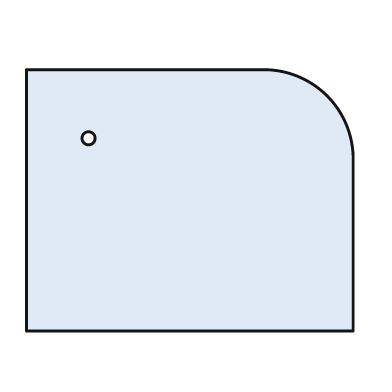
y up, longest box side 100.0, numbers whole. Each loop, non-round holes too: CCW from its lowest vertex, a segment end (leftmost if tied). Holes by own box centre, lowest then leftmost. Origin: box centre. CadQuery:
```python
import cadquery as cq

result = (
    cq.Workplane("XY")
    .moveTo(-50.0, -40.0)
    .lineTo(50.0, -40.0)
    .lineTo(50.0, 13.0)
    .threePointArc((42.0, 32.0), (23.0, 40.0))
    .lineTo(-50.0, 40.0)
    .close()
    .moveTo(-31.0, 19.0)
    .circle(2.0)
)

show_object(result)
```